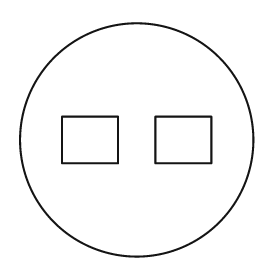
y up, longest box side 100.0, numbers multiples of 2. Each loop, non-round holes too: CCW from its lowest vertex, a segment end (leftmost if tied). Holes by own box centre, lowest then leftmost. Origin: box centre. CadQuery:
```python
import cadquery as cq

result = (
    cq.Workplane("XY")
    .moveTo(0.0, 0.0)
    .circle(50.0)
    .moveTo(-32.0, -10.0)
    .lineTo(-8.0, -10.0)
    .lineTo(-8.0, 10.0)
    .lineTo(-32.0, 10.0)
    .close()
    .moveTo(8.0, -10.0)
    .lineTo(32.0, -10.0)
    .lineTo(32.0, 10.0)
    .lineTo(8.0, 10.0)
    .close()
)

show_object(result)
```